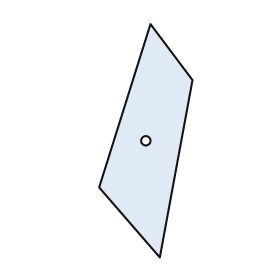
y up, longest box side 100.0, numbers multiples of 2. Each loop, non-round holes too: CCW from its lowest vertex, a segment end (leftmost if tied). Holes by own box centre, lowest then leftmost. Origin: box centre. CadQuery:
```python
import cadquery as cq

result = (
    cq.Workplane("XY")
    .moveTo(6.0, -50.0)
    .lineTo(20.0, 26.0)
    .lineTo(2.0, 50.0)
    .lineTo(-20.0, -20.0)
    .close()
    .moveTo(0.0, 0.0)
    .circle(2.0)
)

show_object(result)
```